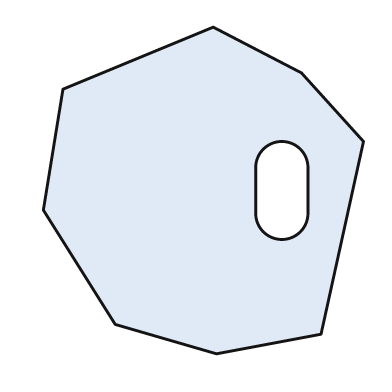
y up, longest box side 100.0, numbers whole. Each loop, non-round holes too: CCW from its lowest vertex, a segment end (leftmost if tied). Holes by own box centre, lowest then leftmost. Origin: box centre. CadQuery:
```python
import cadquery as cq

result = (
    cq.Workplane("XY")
    .moveTo(4.0, -50.0)
    .lineTo(36.0, -44.0)
    .lineTo(49.0, 15.0)
    .lineTo(30.0, 36.0)
    .lineTo(3.0, 50.0)
    .lineTo(-43.0, 31.0)
    .lineTo(-49.0, -6.0)
    .lineTo(-27.0, -41.0)
    .close()
    .moveTo(16.0, -7.0)
    .threePointArc((24.0, -15.0), (32.0, -7.0))
    .lineTo(32.0, 7.0)
    .threePointArc((24.0, 15.0), (16.0, 7.0))
    .close()
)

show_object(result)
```